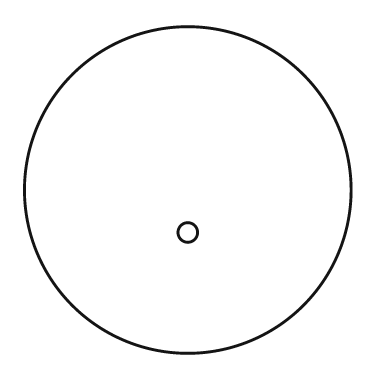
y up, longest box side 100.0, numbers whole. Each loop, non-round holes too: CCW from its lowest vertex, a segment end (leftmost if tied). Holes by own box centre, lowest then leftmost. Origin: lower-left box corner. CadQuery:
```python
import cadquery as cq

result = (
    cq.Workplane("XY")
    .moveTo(50.0, 50.0)
    .circle(50.0)
    .moveTo(50.0, 37.0)
    .circle(3.0)
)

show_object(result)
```